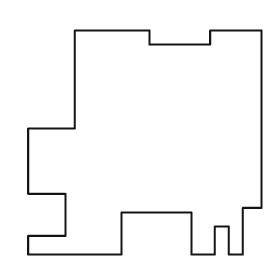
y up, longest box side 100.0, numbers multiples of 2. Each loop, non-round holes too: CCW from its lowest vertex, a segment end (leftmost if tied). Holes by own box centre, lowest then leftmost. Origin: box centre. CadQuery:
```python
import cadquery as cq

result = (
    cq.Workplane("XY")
    .moveTo(-50.0, -48.0)
    .lineTo(-10.0, -48.0)
    .lineTo(-10.0, -30.0)
    .lineTo(20.0, -30.0)
    .lineTo(20.0, -48.0)
    .lineTo(30.0, -48.0)
    .lineTo(30.0, -36.0)
    .lineTo(36.0, -36.0)
    .lineTo(36.0, -48.0)
    .lineTo(42.0, -48.0)
    .lineTo(42.0, -28.0)
    .lineTo(50.0, -28.0)
    .lineTo(50.0, 48.0)
    .lineTo(28.0, 48.0)
    .lineTo(28.0, 42.0)
    .lineTo(2.0, 42.0)
    .lineTo(2.0, 48.0)
    .lineTo(-30.0, 48.0)
    .lineTo(-30.0, 6.0)
    .lineTo(-50.0, 6.0)
    .lineTo(-50.0, -22.0)
    .lineTo(-34.0, -22.0)
    .lineTo(-34.0, -40.0)
    .lineTo(-50.0, -40.0)
    .close()
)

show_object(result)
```